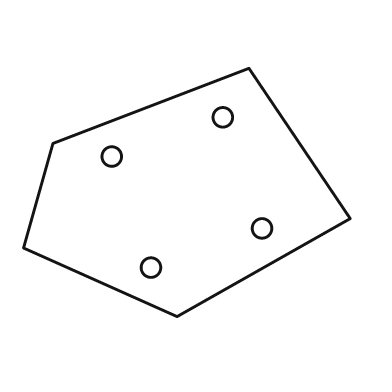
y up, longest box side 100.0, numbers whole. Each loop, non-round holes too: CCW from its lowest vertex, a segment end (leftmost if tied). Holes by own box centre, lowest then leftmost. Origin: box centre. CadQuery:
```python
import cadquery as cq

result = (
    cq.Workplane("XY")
    .moveTo(-3.0, -38.0)
    .lineTo(50.0, -8.0)
    .lineTo(19.0, 38.0)
    .lineTo(-41.0, 15.0)
    .lineTo(-50.0, -17.0)
    .close()
    .moveTo(-11.0, -23.0)
    .circle(3.0)
    .moveTo(23.0, -11.0)
    .circle(3.0)
    .moveTo(-23.0, 11.0)
    .circle(3.0)
    .moveTo(11.0, 23.0)
    .circle(3.0)
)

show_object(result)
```